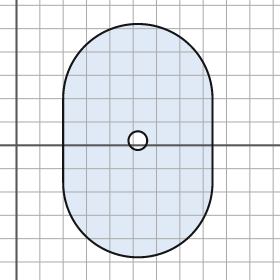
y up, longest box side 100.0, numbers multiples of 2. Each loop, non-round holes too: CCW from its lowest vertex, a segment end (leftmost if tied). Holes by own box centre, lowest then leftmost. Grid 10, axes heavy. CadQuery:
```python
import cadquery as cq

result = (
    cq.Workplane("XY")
    .moveTo(20.0, -16.0)
    .threePointArc((52.0, -48.0), (84.0, -16.0))
    .lineTo(84.0, 20.0)
    .threePointArc((52.0, 52.0), (20.0, 20.0))
    .close()
    .moveTo(52.0, 2.0)
    .circle(4.0)
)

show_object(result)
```